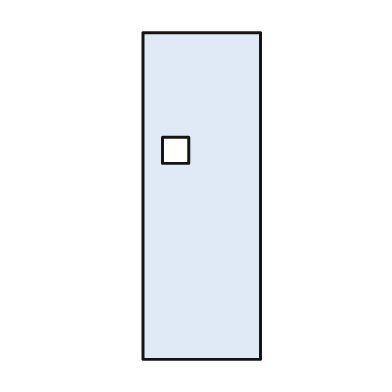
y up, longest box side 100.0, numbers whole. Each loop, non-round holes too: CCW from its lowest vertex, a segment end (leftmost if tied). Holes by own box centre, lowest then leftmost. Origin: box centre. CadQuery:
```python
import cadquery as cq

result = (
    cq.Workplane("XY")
    .moveTo(-18.0, -50.0)
    .lineTo(18.0, -50.0)
    .lineTo(18.0, 50.0)
    .lineTo(-18.0, 50.0)
    .close()
    .moveTo(-12.0, 10.0)
    .lineTo(-4.0, 10.0)
    .lineTo(-4.0, 18.0)
    .lineTo(-12.0, 18.0)
    .close()
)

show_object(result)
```